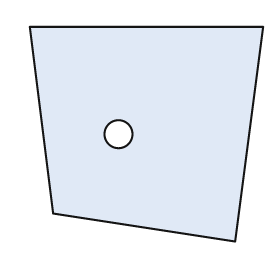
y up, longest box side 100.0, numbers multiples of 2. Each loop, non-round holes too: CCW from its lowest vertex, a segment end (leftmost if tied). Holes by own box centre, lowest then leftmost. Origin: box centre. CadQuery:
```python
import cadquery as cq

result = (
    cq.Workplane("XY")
    .moveTo(38.0, -46.0)
    .lineTo(50.0, 46.0)
    .lineTo(-50.0, 46.0)
    .lineTo(-40.0, -34.0)
    .close()
    .moveTo(-12.0, 0.0)
    .circle(6.0)
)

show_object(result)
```